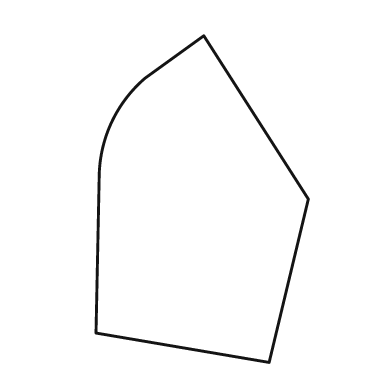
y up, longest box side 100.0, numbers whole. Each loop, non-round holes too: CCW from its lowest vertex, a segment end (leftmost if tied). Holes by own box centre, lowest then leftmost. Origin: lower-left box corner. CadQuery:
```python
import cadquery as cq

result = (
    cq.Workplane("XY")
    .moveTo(53.0, 0.0)
    .lineTo(65.0, 50.0)
    .lineTo(33.0, 100.0)
    .lineTo(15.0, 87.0)
    .threePointArc((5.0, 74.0), (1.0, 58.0))
    .lineTo(0.0, 9.0)
    .close()
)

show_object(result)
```